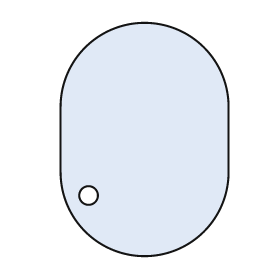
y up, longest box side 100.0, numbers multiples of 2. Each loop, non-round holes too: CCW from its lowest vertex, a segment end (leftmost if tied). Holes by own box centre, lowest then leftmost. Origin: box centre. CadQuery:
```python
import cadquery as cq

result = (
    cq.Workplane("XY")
    .moveTo(-36.0, -14.0)
    .threePointArc((0.0, -50.0), (36.0, -14.0))
    .lineTo(36.0, 14.0)
    .threePointArc((0.0, 50.0), (-36.0, 14.0))
    .close()
    .moveTo(-24.0, -24.0)
    .circle(4.0)
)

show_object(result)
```